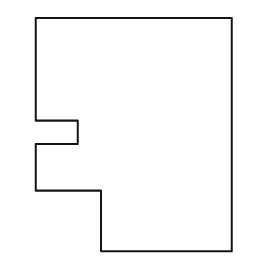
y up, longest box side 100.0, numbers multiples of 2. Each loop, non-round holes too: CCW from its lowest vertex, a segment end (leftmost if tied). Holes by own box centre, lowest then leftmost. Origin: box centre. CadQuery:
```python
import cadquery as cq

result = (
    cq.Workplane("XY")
    .moveTo(-14.0, -50.0)
    .lineTo(42.0, -50.0)
    .lineTo(42.0, 50.0)
    .lineTo(-42.0, 50.0)
    .lineTo(-42.0, 6.0)
    .lineTo(-24.0, 6.0)
    .lineTo(-24.0, -4.0)
    .lineTo(-42.0, -4.0)
    .lineTo(-42.0, -24.0)
    .lineTo(-14.0, -24.0)
    .close()
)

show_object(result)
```